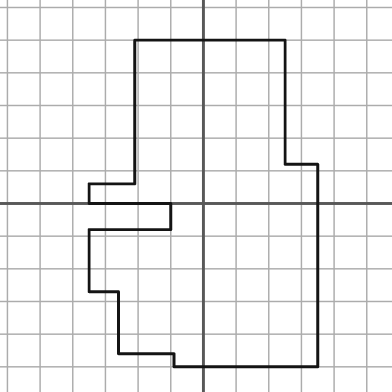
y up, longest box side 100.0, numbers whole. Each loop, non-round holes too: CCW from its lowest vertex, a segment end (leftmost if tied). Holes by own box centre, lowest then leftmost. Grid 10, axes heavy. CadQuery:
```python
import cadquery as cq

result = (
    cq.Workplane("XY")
    .moveTo(-9.0, -50.0)
    .lineTo(35.0, -50.0)
    .lineTo(35.0, 12.0)
    .lineTo(25.0, 12.0)
    .lineTo(25.0, 50.0)
    .lineTo(-21.0, 50.0)
    .lineTo(-21.0, 6.0)
    .lineTo(-35.0, 6.0)
    .lineTo(-35.0, 0.0)
    .lineTo(-10.0, 0.0)
    .lineTo(-10.0, -8.0)
    .lineTo(-35.0, -8.0)
    .lineTo(-35.0, -27.0)
    .lineTo(-26.0, -27.0)
    .lineTo(-26.0, -46.0)
    .lineTo(-9.0, -46.0)
    .close()
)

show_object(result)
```